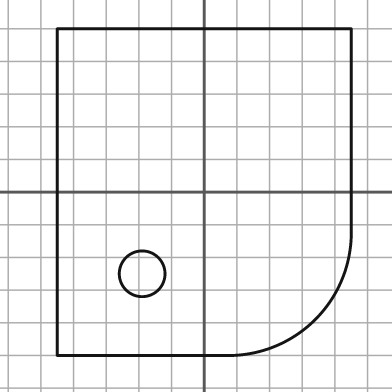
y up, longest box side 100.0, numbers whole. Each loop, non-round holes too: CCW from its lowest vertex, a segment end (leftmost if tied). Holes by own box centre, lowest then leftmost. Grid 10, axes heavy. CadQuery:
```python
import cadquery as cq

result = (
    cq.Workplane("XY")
    .moveTo(-45.0, -50.0)
    .lineTo(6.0, -50.0)
    .threePointArc((34.0, -39.0), (45.0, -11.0))
    .lineTo(45.0, 50.0)
    .lineTo(-45.0, 50.0)
    .close()
    .moveTo(-19.0, -25.0)
    .circle(7.0)
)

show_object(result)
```